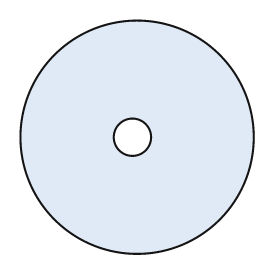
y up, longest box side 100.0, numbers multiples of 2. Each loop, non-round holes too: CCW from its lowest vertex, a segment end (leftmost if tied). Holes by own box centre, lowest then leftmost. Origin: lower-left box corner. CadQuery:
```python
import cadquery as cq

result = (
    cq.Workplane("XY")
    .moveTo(50.0, 50.0)
    .circle(50.0)
    .moveTo(48.0, 50.0)
    .circle(8.0)
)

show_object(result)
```